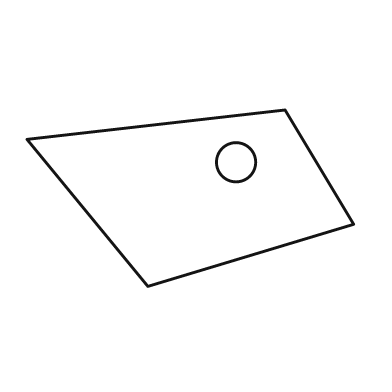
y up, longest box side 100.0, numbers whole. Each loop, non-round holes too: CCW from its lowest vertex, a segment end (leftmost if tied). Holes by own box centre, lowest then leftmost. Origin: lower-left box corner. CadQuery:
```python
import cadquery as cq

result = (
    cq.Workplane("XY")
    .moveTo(37.0, 0.0)
    .lineTo(100.0, 19.0)
    .lineTo(79.0, 54.0)
    .lineTo(0.0, 45.0)
    .close()
    .moveTo(64.0, 38.0)
    .circle(6.0)
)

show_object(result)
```